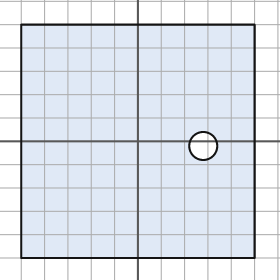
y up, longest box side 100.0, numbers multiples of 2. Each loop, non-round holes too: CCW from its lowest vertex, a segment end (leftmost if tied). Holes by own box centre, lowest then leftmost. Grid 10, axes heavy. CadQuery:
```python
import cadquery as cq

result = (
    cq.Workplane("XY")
    .moveTo(-50.0, -50.0)
    .lineTo(50.0, -50.0)
    .lineTo(50.0, 50.0)
    .lineTo(-50.0, 50.0)
    .close()
    .moveTo(28.0, -2.0)
    .circle(6.0)
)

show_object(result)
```